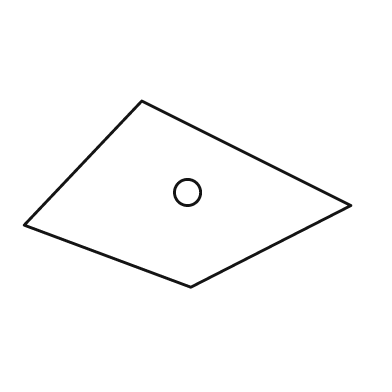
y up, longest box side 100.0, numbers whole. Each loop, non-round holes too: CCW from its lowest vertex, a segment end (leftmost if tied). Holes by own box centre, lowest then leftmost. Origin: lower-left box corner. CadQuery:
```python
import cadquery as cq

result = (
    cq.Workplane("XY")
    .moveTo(51.0, 0.0)
    .lineTo(100.0, 25.0)
    .lineTo(36.0, 57.0)
    .lineTo(0.0, 19.0)
    .close()
    .moveTo(50.0, 29.0)
    .circle(4.0)
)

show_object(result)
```